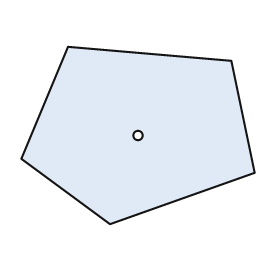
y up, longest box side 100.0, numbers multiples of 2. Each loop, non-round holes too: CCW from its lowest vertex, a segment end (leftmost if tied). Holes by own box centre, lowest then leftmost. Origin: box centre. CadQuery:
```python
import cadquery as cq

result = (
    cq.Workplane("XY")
    .moveTo(-12.0, -38.0)
    .lineTo(50.0, -16.0)
    .lineTo(40.0, 32.0)
    .lineTo(-30.0, 38.0)
    .lineTo(-50.0, -10.0)
    .close()
    .moveTo(0.0, 0.0)
    .circle(2.0)
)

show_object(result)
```